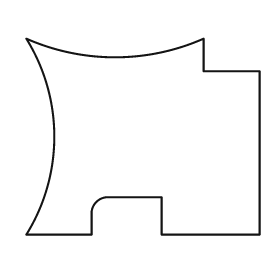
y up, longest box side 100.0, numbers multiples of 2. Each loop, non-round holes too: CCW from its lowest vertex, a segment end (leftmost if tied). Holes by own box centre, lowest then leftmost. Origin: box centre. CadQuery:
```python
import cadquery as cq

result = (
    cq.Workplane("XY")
    .moveTo(-50.0, -42.0)
    .lineTo(-22.0, -42.0)
    .lineTo(-22.0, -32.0)
    .threePointArc((-20.0, -28.0), (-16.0, -26.0))
    .lineTo(8.0, -26.0)
    .lineTo(8.0, -42.0)
    .lineTo(50.0, -42.0)
    .lineTo(50.0, 28.0)
    .lineTo(26.0, 28.0)
    .lineTo(26.0, 42.0)
    .threePointArc((-12.0, 34.0), (-50.0, 42.0))
    .threePointArc((-38.0, 0.0), (-50.0, -42.0))
    .close()
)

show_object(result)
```